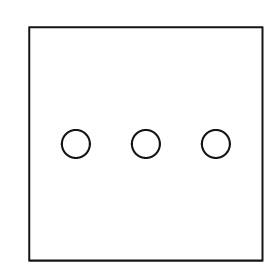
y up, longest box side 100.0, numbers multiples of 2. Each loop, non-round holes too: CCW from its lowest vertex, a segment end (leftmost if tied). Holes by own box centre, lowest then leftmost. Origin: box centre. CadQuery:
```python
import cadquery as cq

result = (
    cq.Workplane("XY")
    .moveTo(-50.0, -50.0)
    .lineTo(50.0, -50.0)
    .lineTo(50.0, 50.0)
    .lineTo(-50.0, 50.0)
    .close()
    .moveTo(-30.0, 0.0)
    .circle(6.0)
    .moveTo(0.0, 0.0)
    .circle(6.0)
    .moveTo(30.0, 0.0)
    .circle(6.0)
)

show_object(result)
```